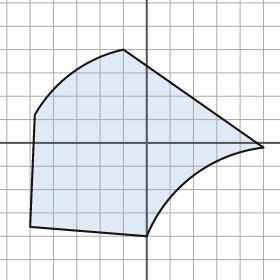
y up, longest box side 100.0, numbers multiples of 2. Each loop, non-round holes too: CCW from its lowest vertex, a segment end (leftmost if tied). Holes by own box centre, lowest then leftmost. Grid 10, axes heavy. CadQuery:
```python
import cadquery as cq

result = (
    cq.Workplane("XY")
    .moveTo(0.0, -40.0)
    .threePointArc((20.0, -14.0), (50.0, -2.0))
    .lineTo(-10.0, 40.0)
    .threePointArc((-32.0, 30.0), (-48.0, 12.0))
    .lineTo(-50.0, -36.0)
    .close()
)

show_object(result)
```